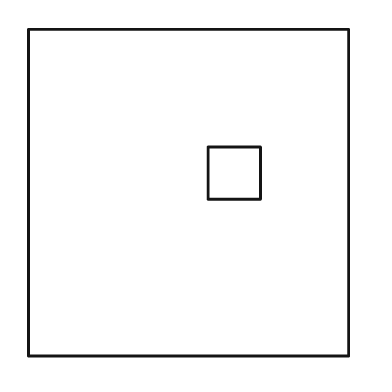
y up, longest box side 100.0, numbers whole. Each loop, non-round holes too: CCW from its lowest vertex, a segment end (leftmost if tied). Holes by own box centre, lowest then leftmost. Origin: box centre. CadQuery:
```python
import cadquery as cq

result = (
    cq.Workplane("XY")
    .moveTo(-49.0, -50.0)
    .lineTo(49.0, -50.0)
    .lineTo(49.0, 50.0)
    .lineTo(-49.0, 50.0)
    .close()
    .moveTo(6.0, -2.0)
    .lineTo(22.0, -2.0)
    .lineTo(22.0, 14.0)
    .lineTo(6.0, 14.0)
    .close()
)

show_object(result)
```